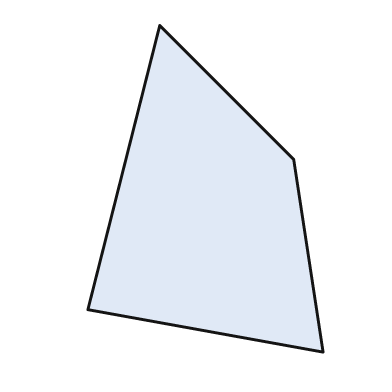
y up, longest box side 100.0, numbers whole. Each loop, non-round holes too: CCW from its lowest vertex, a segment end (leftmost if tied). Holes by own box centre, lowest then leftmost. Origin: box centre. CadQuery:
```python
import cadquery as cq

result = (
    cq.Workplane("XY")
    .moveTo(36.0, -50.0)
    .lineTo(27.0, 9.0)
    .lineTo(-14.0, 50.0)
    .lineTo(-36.0, -37.0)
    .close()
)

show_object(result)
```